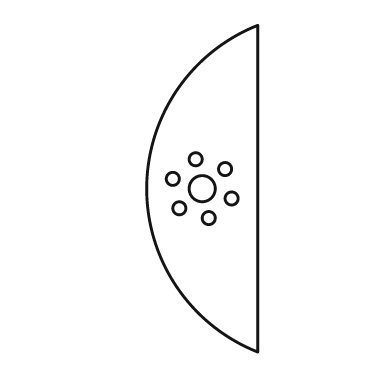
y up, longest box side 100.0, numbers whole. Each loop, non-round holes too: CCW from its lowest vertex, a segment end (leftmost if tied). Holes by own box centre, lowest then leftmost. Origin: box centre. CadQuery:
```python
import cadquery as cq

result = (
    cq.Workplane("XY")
    .moveTo(17.0, -50.0)
    .lineTo(17.0, 50.0)
    .threePointArc((-17.0, 0.0), (17.0, -50.0))
    .close()
    .moveTo(2.0, -9.0)
    .circle(2.0)
    .moveTo(-7.0, -6.0)
    .circle(2.0)
    .moveTo(9.0, -3.0)
    .circle(2.0)
    .moveTo(0.0, 0.0)
    .circle(4.0)
    .moveTo(-9.0, 3.0)
    .circle(2.0)
    .moveTo(7.0, 6.0)
    .circle(2.0)
    .moveTo(-2.0, 9.0)
    .circle(2.0)
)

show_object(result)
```